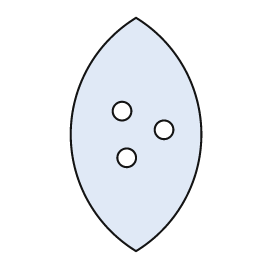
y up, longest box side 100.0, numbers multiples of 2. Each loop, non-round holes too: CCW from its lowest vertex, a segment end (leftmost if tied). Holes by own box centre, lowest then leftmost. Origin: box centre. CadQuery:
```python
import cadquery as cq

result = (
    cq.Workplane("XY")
    .moveTo(0.0, -50.0)
    .threePointArc((28.0, 0.0), (0.0, 50.0))
    .threePointArc((-28.0, 0.0), (0.0, -50.0))
    .close()
    .moveTo(-4.0, -10.0)
    .circle(4.0)
    .moveTo(12.0, 2.0)
    .circle(4.0)
    .moveTo(-6.0, 10.0)
    .circle(4.0)
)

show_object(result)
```